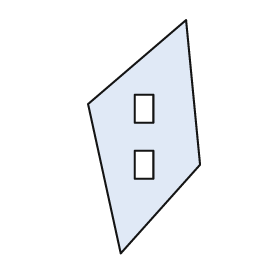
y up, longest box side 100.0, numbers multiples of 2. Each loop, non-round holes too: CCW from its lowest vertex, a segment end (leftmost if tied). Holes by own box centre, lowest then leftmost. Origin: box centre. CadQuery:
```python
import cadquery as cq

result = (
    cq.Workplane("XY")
    .moveTo(-10.0, -50.0)
    .lineTo(24.0, -12.0)
    .lineTo(18.0, 50.0)
    .lineTo(-24.0, 14.0)
    .close()
    .moveTo(-4.0, -18.0)
    .lineTo(4.0, -18.0)
    .lineTo(4.0, -6.0)
    .lineTo(-4.0, -6.0)
    .close()
    .moveTo(-4.0, 6.0)
    .lineTo(4.0, 6.0)
    .lineTo(4.0, 18.0)
    .lineTo(-4.0, 18.0)
    .close()
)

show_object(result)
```